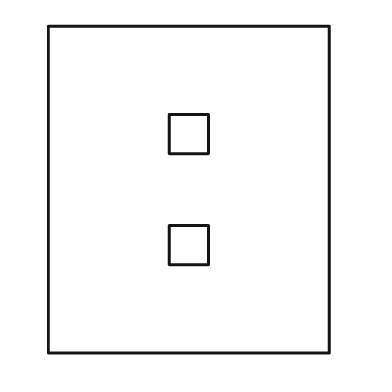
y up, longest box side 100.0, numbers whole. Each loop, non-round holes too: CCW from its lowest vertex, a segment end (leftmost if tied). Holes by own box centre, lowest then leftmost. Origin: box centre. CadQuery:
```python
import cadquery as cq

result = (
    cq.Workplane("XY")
    .moveTo(-43.0, -50.0)
    .lineTo(43.0, -50.0)
    .lineTo(43.0, 50.0)
    .lineTo(-43.0, 50.0)
    .close()
    .moveTo(-6.0, -23.0)
    .lineTo(6.0, -23.0)
    .lineTo(6.0, -11.0)
    .lineTo(-6.0, -11.0)
    .close()
    .moveTo(-6.0, 11.0)
    .lineTo(6.0, 11.0)
    .lineTo(6.0, 23.0)
    .lineTo(-6.0, 23.0)
    .close()
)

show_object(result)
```